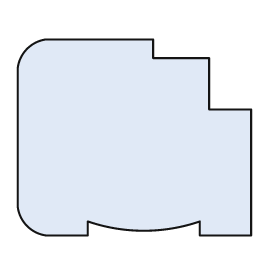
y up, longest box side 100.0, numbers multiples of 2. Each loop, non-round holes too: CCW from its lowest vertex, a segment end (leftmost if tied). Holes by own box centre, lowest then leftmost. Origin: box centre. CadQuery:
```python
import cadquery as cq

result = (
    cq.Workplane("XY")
    .moveTo(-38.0, -42.0)
    .lineTo(-20.0, -42.0)
    .lineTo(-20.0, -36.0)
    .threePointArc((4.0, -40.0), (28.0, -36.0))
    .lineTo(28.0, -42.0)
    .lineTo(50.0, -42.0)
    .lineTo(50.0, 12.0)
    .lineTo(32.0, 12.0)
    .lineTo(32.0, 34.0)
    .lineTo(8.0, 34.0)
    .lineTo(8.0, 42.0)
    .lineTo(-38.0, 42.0)
    .threePointArc((-46.0, 38.0), (-50.0, 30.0))
    .lineTo(-50.0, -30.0)
    .threePointArc((-46.0, -38.0), (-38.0, -42.0))
    .close()
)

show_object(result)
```